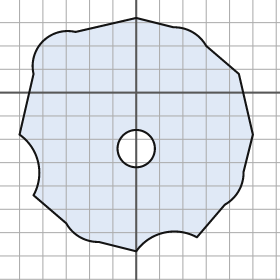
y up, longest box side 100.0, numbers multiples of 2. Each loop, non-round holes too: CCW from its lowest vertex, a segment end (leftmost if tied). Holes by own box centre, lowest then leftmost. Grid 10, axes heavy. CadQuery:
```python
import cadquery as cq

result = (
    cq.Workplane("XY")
    .moveTo(0.0, -68.0)
    .threePointArc((12.0, -60.0), (26.0, -62.0))
    .lineTo(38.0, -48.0)
    .threePointArc((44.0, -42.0), (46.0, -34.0))
    .lineTo(50.0, -18.0)
    .lineTo(44.0, 8.0)
    .lineTo(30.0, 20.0)
    .threePointArc((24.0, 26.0), (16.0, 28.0))
    .lineTo(0.0, 32.0)
    .lineTo(-26.0, 26.0)
    .threePointArc((-40.0, 22.0), (-44.0, 8.0))
    .lineTo(-50.0, -18.0)
    .threePointArc((-42.0, -30.0), (-44.0, -44.0))
    .lineTo(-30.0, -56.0)
    .threePointArc((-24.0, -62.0), (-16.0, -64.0))
    .close()
    .moveTo(0.0, -24.0)
    .circle(8.0)
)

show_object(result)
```